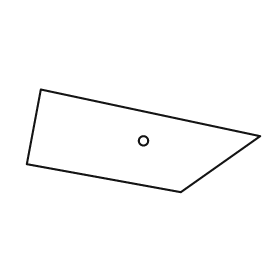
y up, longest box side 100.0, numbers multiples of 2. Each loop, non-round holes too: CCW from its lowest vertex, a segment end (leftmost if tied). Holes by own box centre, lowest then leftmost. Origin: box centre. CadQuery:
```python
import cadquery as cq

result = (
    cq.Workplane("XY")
    .moveTo(16.0, -22.0)
    .lineTo(50.0, 2.0)
    .lineTo(-44.0, 22.0)
    .lineTo(-50.0, -10.0)
    .close()
    .moveTo(0.0, 0.0)
    .circle(2.0)
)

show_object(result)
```